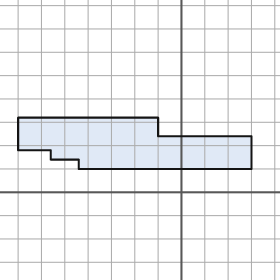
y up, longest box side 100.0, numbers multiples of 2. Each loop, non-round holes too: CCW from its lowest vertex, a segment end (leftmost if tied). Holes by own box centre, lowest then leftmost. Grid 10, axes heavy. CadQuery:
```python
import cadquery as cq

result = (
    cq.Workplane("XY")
    .moveTo(-44.0, 10.0)
    .lineTo(30.0, 10.0)
    .lineTo(30.0, 24.0)
    .lineTo(-10.0, 24.0)
    .lineTo(-10.0, 32.0)
    .lineTo(-70.0, 32.0)
    .lineTo(-70.0, 18.0)
    .lineTo(-56.0, 18.0)
    .lineTo(-56.0, 14.0)
    .lineTo(-44.0, 14.0)
    .close()
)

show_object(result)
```